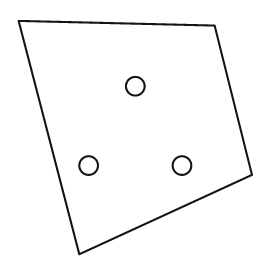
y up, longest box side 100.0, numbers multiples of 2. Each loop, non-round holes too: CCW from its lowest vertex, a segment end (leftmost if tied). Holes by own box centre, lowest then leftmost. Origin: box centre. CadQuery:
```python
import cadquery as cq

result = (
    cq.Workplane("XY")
    .moveTo(-24.0, -50.0)
    .lineTo(50.0, -16.0)
    .lineTo(34.0, 48.0)
    .lineTo(-50.0, 50.0)
    .close()
    .moveTo(-20.0, -12.0)
    .circle(4.0)
    .moveTo(20.0, -12.0)
    .circle(4.0)
    .moveTo(0.0, 22.0)
    .circle(4.0)
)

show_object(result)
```